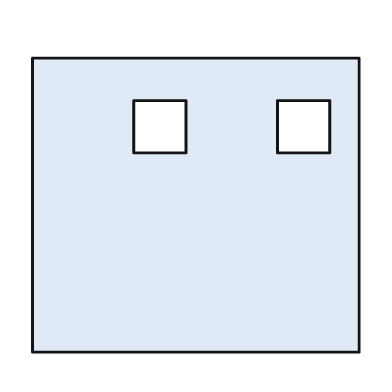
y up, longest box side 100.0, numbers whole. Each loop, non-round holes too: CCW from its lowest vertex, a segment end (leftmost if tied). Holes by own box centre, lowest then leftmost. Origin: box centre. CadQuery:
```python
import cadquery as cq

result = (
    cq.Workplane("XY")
    .moveTo(-50.0, -45.0)
    .lineTo(50.0, -45.0)
    .lineTo(50.0, 45.0)
    .lineTo(-50.0, 45.0)
    .close()
    .moveTo(-19.0, 16.0)
    .lineTo(-3.0, 16.0)
    .lineTo(-3.0, 32.0)
    .lineTo(-19.0, 32.0)
    .close()
    .moveTo(25.0, 16.0)
    .lineTo(41.0, 16.0)
    .lineTo(41.0, 32.0)
    .lineTo(25.0, 32.0)
    .close()
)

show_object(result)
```